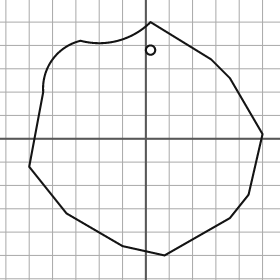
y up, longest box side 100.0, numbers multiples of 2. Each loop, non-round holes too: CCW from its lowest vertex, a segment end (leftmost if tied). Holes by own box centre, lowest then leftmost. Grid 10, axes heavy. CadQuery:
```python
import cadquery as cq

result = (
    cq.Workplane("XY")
    .moveTo(8.0, -50.0)
    .lineTo(36.0, -34.0)
    .lineTo(44.0, -24.0)
    .lineTo(50.0, 2.0)
    .lineTo(36.0, 26.0)
    .lineTo(28.0, 34.0)
    .lineTo(2.0, 50.0)
    .threePointArc((-12.0, 42.0), (-28.0, 42.0))
    .threePointArc((-40.0, 34.0), (-44.0, 20.0))
    .lineTo(-50.0, -12.0)
    .lineTo(-34.0, -32.0)
    .lineTo(-10.0, -46.0)
    .close()
    .moveTo(2.0, 38.0)
    .circle(2.0)
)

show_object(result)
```